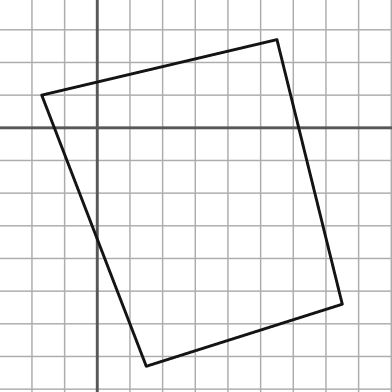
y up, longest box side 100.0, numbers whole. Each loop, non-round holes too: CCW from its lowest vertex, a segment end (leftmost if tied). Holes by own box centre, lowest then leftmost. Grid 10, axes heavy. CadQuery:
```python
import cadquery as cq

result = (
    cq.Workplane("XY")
    .moveTo(15.0, -73.0)
    .lineTo(75.0, -54.0)
    .lineTo(55.0, 27.0)
    .lineTo(-17.0, 10.0)
    .close()
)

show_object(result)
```